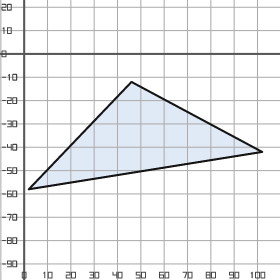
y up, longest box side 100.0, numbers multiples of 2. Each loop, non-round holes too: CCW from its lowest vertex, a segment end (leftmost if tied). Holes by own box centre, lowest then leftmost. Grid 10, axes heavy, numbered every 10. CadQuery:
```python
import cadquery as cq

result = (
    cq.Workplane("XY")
    .moveTo(2.0, -58.0)
    .lineTo(102.0, -42.0)
    .lineTo(46.0, -12.0)
    .close()
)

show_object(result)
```